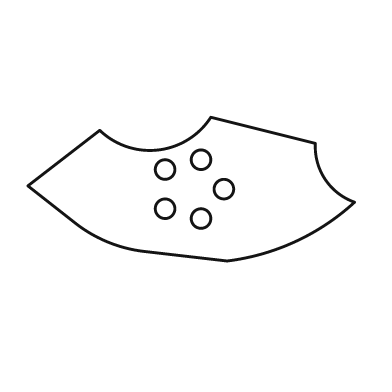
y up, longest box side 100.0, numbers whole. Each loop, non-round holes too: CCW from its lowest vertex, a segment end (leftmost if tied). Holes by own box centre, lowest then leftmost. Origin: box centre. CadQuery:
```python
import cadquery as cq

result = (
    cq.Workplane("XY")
    .moveTo(11.0, -22.0)
    .threePointArc((32.0, -16.0), (50.0, -4.0))
    .threePointArc((41.0, 3.0), (38.0, 14.0))
    .lineTo(6.0, 22.0)
    .threePointArc((-10.0, 12.0), (-28.0, 18.0))
    .lineTo(-50.0, 1.0)
    .lineTo(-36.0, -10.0)
    .threePointArc((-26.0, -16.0), (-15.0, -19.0))
    .close()
    .moveTo(3.0, -9.0)
    .circle(3.0)
    .moveTo(-8.0, -6.0)
    .circle(3.0)
    .moveTo(10.0, 0.0)
    .circle(3.0)
    .moveTo(-8.0, 6.0)
    .circle(3.0)
    .moveTo(3.0, 9.0)
    .circle(3.0)
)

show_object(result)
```